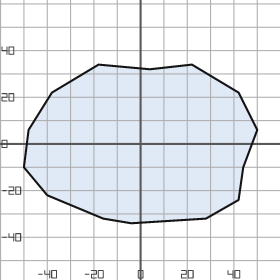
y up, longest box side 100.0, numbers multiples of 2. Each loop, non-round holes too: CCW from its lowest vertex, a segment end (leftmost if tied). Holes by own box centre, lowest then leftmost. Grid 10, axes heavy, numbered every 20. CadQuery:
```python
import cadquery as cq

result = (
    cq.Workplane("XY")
    .moveTo(-4.0, -34.0)
    .lineTo(28.0, -32.0)
    .lineTo(42.0, -24.0)
    .lineTo(44.0, -10.0)
    .lineTo(50.0, 6.0)
    .lineTo(42.0, 22.0)
    .lineTo(22.0, 34.0)
    .lineTo(4.0, 32.0)
    .lineTo(-18.0, 34.0)
    .lineTo(-38.0, 22.0)
    .lineTo(-48.0, 6.0)
    .lineTo(-50.0, -10.0)
    .lineTo(-40.0, -22.0)
    .lineTo(-16.0, -32.0)
    .close()
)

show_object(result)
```